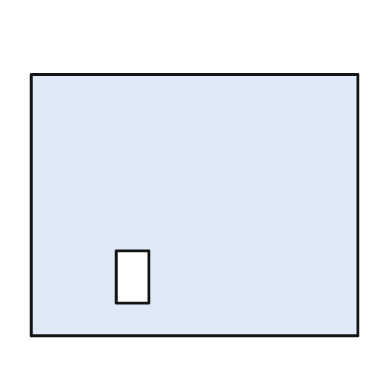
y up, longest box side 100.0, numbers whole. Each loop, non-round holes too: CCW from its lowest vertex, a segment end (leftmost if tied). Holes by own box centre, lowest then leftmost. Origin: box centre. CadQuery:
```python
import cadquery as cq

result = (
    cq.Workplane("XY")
    .moveTo(-50.0, -40.0)
    .lineTo(50.0, -40.0)
    .lineTo(50.0, 40.0)
    .lineTo(-50.0, 40.0)
    .close()
    .moveTo(-24.0, -30.0)
    .lineTo(-14.0, -30.0)
    .lineTo(-14.0, -14.0)
    .lineTo(-24.0, -14.0)
    .close()
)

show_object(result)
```